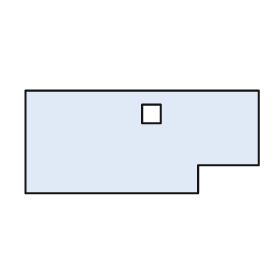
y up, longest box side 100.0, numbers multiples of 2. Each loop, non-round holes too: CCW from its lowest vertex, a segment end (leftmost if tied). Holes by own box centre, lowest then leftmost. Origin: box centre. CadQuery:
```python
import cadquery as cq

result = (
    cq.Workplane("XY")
    .moveTo(-50.0, -22.0)
    .lineTo(24.0, -22.0)
    .lineTo(24.0, -10.0)
    .lineTo(50.0, -10.0)
    .lineTo(50.0, 22.0)
    .lineTo(-50.0, 22.0)
    .close()
    .moveTo(0.0, 8.0)
    .lineTo(8.0, 8.0)
    .lineTo(8.0, 16.0)
    .lineTo(0.0, 16.0)
    .close()
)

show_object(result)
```